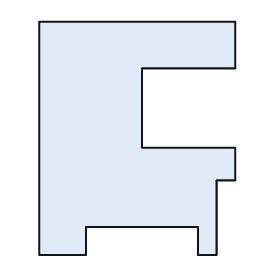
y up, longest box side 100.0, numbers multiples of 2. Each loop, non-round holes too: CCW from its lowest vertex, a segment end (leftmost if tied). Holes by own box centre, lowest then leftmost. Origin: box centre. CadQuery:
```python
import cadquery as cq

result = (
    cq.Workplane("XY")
    .moveTo(-42.0, -50.0)
    .lineTo(-22.0, -50.0)
    .lineTo(-22.0, -38.0)
    .lineTo(26.0, -38.0)
    .lineTo(26.0, -50.0)
    .lineTo(34.0, -50.0)
    .lineTo(34.0, -18.0)
    .lineTo(42.0, -18.0)
    .lineTo(42.0, -4.0)
    .lineTo(2.0, -4.0)
    .lineTo(2.0, 30.0)
    .lineTo(42.0, 30.0)
    .lineTo(42.0, 50.0)
    .lineTo(-42.0, 50.0)
    .close()
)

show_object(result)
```